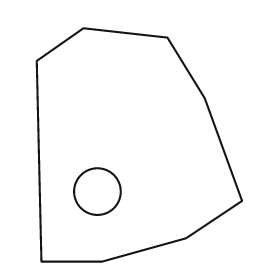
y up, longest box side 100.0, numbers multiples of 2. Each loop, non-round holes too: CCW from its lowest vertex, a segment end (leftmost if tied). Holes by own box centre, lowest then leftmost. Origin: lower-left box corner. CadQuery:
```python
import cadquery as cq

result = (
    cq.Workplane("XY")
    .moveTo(2.0, 0.0)
    .lineTo(28.0, 0.0)
    .lineTo(64.0, 10.0)
    .lineTo(88.0, 26.0)
    .lineTo(72.0, 70.0)
    .lineTo(56.0, 96.0)
    .lineTo(20.0, 100.0)
    .lineTo(0.0, 86.0)
    .close()
    .moveTo(26.0, 30.0)
    .circle(10.0)
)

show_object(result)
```